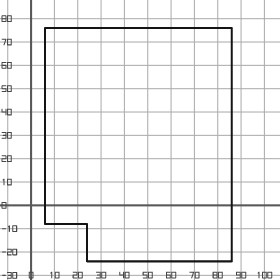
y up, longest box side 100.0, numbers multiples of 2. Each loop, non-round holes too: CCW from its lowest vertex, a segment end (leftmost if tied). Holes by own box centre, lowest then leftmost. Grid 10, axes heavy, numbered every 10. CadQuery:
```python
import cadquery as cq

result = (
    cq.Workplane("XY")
    .moveTo(24.0, -24.0)
    .lineTo(86.0, -24.0)
    .lineTo(86.0, 76.0)
    .lineTo(6.0, 76.0)
    .lineTo(6.0, -8.0)
    .lineTo(24.0, -8.0)
    .close()
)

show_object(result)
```